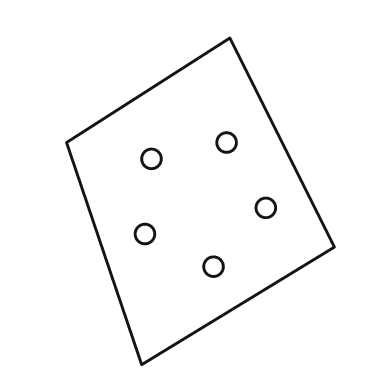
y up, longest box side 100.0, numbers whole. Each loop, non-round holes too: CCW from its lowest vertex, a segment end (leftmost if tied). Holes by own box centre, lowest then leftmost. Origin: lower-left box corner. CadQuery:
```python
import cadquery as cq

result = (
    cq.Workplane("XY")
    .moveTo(23.0, 0.0)
    .lineTo(82.0, 36.0)
    .lineTo(50.0, 100.0)
    .lineTo(0.0, 68.0)
    .close()
    .moveTo(45.0, 30.0)
    .circle(3.0)
    .moveTo(24.0, 40.0)
    .circle(3.0)
    .moveTo(61.0, 48.0)
    .circle(3.0)
    .moveTo(26.0, 63.0)
    .circle(3.0)
    .moveTo(49.0, 68.0)
    .circle(3.0)
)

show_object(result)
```